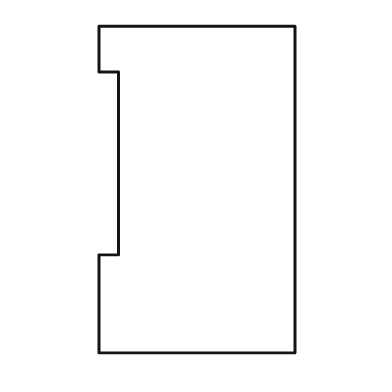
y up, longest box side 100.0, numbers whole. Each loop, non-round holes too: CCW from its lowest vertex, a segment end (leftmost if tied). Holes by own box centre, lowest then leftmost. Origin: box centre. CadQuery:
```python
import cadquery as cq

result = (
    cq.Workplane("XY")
    .moveTo(-30.0, -50.0)
    .lineTo(30.0, -50.0)
    .lineTo(30.0, 50.0)
    .lineTo(-30.0, 50.0)
    .lineTo(-30.0, 36.0)
    .lineTo(-24.0, 36.0)
    .lineTo(-24.0, -20.0)
    .lineTo(-30.0, -20.0)
    .close()
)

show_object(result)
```